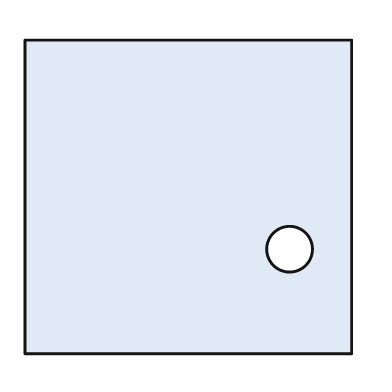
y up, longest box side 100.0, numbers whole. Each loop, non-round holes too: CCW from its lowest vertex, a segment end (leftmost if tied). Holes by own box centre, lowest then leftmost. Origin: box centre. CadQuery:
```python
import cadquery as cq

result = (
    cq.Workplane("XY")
    .moveTo(-50.0, -48.0)
    .lineTo(50.0, -48.0)
    .lineTo(50.0, 48.0)
    .lineTo(-50.0, 48.0)
    .close()
    .moveTo(31.0, -16.0)
    .circle(7.0)
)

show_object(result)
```